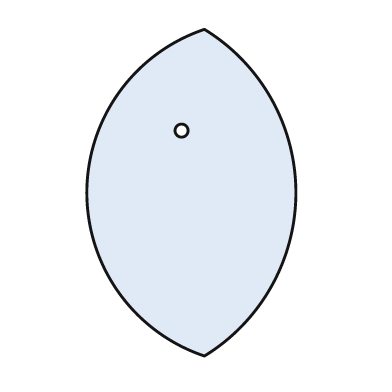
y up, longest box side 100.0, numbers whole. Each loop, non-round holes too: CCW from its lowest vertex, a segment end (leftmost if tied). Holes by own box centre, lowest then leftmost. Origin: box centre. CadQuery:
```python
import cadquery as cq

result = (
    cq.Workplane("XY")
    .moveTo(4.0, -50.0)
    .threePointArc((32.0, 0.0), (4.0, 50.0))
    .threePointArc((-32.0, 0.0), (4.0, -50.0))
    .close()
    .moveTo(-3.0, 19.0)
    .circle(2.0)
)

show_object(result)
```